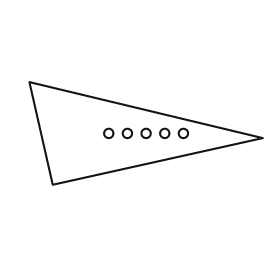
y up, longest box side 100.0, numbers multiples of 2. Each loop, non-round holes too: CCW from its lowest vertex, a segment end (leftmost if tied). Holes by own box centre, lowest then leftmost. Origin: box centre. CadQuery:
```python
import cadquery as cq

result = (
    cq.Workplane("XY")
    .moveTo(-40.0, -22.0)
    .lineTo(50.0, -2.0)
    .lineTo(-50.0, 22.0)
    .close()
    .moveTo(-16.0, 0.0)
    .circle(2.0)
    .moveTo(-8.0, 0.0)
    .circle(2.0)
    .moveTo(0.0, 0.0)
    .circle(2.0)
    .moveTo(8.0, 0.0)
    .circle(2.0)
    .moveTo(16.0, 0.0)
    .circle(2.0)
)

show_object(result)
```